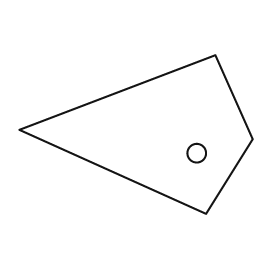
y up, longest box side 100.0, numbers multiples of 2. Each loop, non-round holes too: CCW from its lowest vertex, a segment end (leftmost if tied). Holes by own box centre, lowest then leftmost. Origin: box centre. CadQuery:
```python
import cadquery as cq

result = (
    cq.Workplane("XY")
    .moveTo(30.0, -34.0)
    .lineTo(50.0, -2.0)
    .lineTo(34.0, 34.0)
    .lineTo(-50.0, 2.0)
    .close()
    .moveTo(26.0, -8.0)
    .circle(4.0)
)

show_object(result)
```